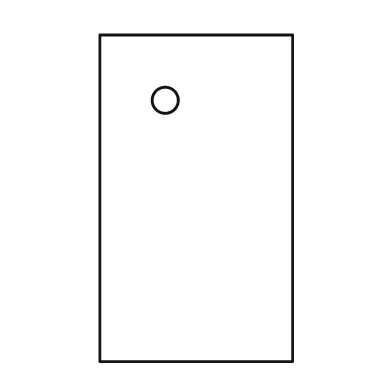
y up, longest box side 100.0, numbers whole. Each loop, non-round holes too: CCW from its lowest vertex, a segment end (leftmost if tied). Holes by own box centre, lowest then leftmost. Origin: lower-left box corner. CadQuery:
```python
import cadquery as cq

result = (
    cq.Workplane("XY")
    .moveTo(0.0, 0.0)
    .lineTo(59.0, 0.0)
    .lineTo(59.0, 100.0)
    .lineTo(0.0, 100.0)
    .close()
    .moveTo(20.0, 80.0)
    .circle(4.0)
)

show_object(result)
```